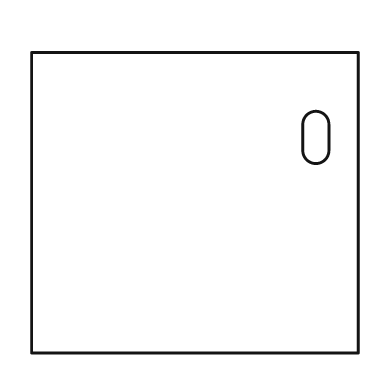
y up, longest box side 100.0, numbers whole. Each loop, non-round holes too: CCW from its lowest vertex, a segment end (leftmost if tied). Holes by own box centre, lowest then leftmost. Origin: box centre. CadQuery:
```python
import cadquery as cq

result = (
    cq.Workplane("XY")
    .moveTo(-50.0, -46.0)
    .lineTo(50.0, -46.0)
    .lineTo(50.0, 46.0)
    .lineTo(-50.0, 46.0)
    .close()
    .moveTo(33.0, 16.0)
    .threePointArc((37.0, 12.0), (41.0, 16.0))
    .lineTo(41.0, 24.0)
    .threePointArc((37.0, 28.0), (33.0, 24.0))
    .close()
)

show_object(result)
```